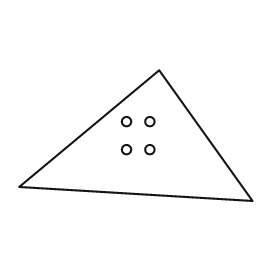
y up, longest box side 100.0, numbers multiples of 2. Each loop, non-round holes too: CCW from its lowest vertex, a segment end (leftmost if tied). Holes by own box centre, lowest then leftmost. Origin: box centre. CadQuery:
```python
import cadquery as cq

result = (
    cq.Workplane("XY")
    .moveTo(50.0, -28.0)
    .lineTo(10.0, 28.0)
    .lineTo(-50.0, -22.0)
    .close()
    .moveTo(-4.0, -6.0)
    .circle(2.0)
    .moveTo(6.0, -6.0)
    .circle(2.0)
    .moveTo(-4.0, 6.0)
    .circle(2.0)
    .moveTo(6.0, 6.0)
    .circle(2.0)
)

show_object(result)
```